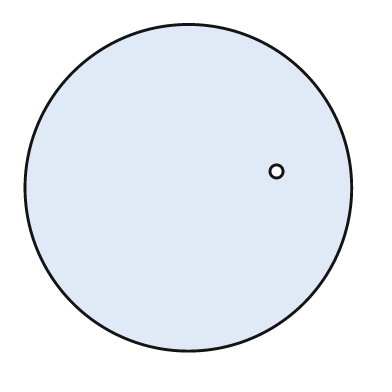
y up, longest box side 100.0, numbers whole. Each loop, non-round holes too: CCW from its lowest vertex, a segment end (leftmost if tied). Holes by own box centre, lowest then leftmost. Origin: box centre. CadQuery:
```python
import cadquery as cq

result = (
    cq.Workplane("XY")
    .moveTo(0.0, 0.0)
    .circle(50.0)
    .moveTo(27.0, 5.0)
    .circle(2.0)
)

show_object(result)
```